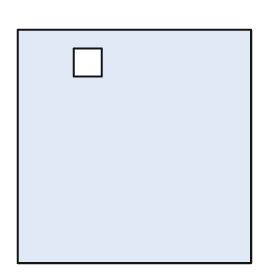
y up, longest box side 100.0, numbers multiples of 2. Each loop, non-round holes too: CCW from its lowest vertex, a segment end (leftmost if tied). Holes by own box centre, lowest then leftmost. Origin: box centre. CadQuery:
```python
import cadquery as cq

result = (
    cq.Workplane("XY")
    .moveTo(-50.0, -50.0)
    .lineTo(50.0, -50.0)
    .lineTo(50.0, 50.0)
    .lineTo(-50.0, 50.0)
    .close()
    .moveTo(-26.0, 30.0)
    .lineTo(-14.0, 30.0)
    .lineTo(-14.0, 42.0)
    .lineTo(-26.0, 42.0)
    .close()
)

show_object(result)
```